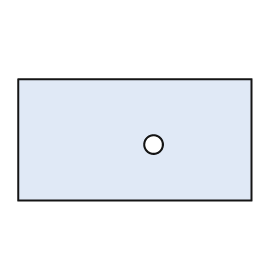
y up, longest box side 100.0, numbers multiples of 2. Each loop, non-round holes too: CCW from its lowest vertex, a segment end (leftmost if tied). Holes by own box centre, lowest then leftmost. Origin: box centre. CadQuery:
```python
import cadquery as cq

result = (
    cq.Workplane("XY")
    .moveTo(-50.0, -26.0)
    .lineTo(50.0, -26.0)
    .lineTo(50.0, 26.0)
    .lineTo(-50.0, 26.0)
    .close()
    .moveTo(8.0, -2.0)
    .circle(4.0)
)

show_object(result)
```